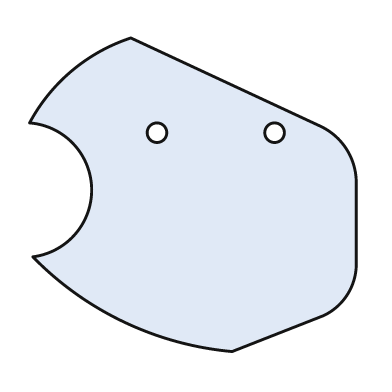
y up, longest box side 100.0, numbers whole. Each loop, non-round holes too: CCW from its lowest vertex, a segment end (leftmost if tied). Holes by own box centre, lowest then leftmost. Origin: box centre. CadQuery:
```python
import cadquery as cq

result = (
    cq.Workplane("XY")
    .moveTo(12.0, -48.0)
    .lineTo(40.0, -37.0)
    .threePointArc((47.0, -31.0), (50.0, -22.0))
    .lineTo(50.0, 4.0)
    .threePointArc((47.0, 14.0), (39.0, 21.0))
    .lineTo(-19.0, 48.0)
    .threePointArc((-37.0, 38.0), (-50.0, 22.0))
    .threePointArc((-31.0, 2.0), (-49.0, -19.0))
    .threePointArc((-21.0, -39.0), (12.0, -48.0))
    .close()
    .moveTo(-11.0, 19.0)
    .circle(3.0)
    .moveTo(25.0, 19.0)
    .circle(3.0)
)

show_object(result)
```